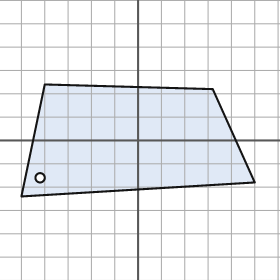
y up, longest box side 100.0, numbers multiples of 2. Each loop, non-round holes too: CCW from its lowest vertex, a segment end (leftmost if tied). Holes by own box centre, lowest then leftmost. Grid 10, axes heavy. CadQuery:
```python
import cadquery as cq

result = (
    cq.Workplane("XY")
    .moveTo(-50.0, -24.0)
    .lineTo(50.0, -18.0)
    .lineTo(32.0, 22.0)
    .lineTo(-40.0, 24.0)
    .close()
    .moveTo(-42.0, -16.0)
    .circle(2.0)
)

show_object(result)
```